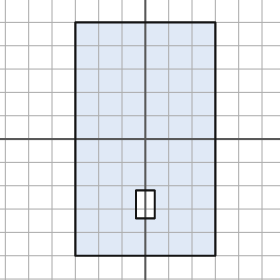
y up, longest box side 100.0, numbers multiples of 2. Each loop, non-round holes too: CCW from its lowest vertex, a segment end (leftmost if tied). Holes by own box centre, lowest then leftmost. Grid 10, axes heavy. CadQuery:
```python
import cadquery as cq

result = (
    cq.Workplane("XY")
    .moveTo(-30.0, -50.0)
    .lineTo(30.0, -50.0)
    .lineTo(30.0, 50.0)
    .lineTo(-30.0, 50.0)
    .close()
    .moveTo(-4.0, -34.0)
    .lineTo(4.0, -34.0)
    .lineTo(4.0, -22.0)
    .lineTo(-4.0, -22.0)
    .close()
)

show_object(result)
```